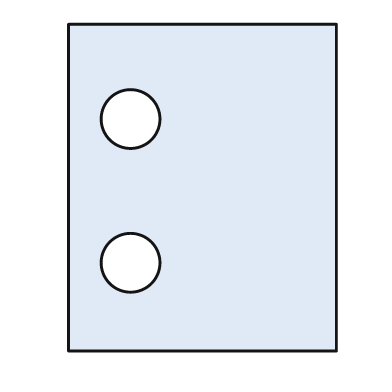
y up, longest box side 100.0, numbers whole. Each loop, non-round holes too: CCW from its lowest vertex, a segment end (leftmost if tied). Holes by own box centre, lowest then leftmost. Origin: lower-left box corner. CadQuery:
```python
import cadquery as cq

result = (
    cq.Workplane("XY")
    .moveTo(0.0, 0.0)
    .lineTo(82.0, 0.0)
    .lineTo(82.0, 100.0)
    .lineTo(0.0, 100.0)
    .close()
    .moveTo(19.0, 27.0)
    .circle(9.0)
    .moveTo(19.0, 71.0)
    .circle(9.0)
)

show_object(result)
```